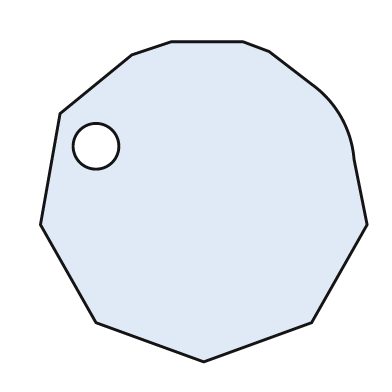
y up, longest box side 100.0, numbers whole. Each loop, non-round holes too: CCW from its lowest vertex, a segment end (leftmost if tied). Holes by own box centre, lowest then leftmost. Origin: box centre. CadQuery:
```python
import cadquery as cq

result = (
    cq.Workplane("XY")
    .moveTo(0.0, -49.0)
    .lineTo(33.0, -37.0)
    .lineTo(50.0, -7.0)
    .lineTo(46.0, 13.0)
    .threePointArc((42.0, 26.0), (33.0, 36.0))
    .lineTo(20.0, 46.0)
    .lineTo(12.0, 49.0)
    .lineTo(-10.0, 49.0)
    .lineTo(-22.0, 45.0)
    .lineTo(-44.0, 27.0)
    .lineTo(-50.0, -7.0)
    .lineTo(-33.0, -37.0)
    .close()
    .moveTo(-33.0, 17.0)
    .circle(7.0)
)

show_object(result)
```